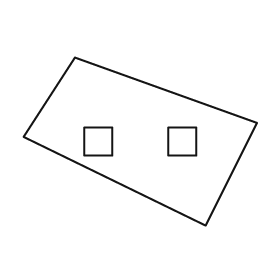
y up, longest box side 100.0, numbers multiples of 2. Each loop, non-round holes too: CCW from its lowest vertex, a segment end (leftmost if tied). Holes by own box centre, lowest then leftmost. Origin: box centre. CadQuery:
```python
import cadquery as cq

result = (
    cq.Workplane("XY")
    .moveTo(28.0, -36.0)
    .lineTo(50.0, 8.0)
    .lineTo(-28.0, 36.0)
    .lineTo(-50.0, 2.0)
    .close()
    .moveTo(-24.0, -6.0)
    .lineTo(-12.0, -6.0)
    .lineTo(-12.0, 6.0)
    .lineTo(-24.0, 6.0)
    .close()
    .moveTo(12.0, -6.0)
    .lineTo(24.0, -6.0)
    .lineTo(24.0, 6.0)
    .lineTo(12.0, 6.0)
    .close()
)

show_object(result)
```